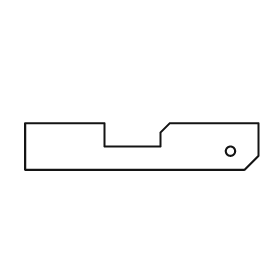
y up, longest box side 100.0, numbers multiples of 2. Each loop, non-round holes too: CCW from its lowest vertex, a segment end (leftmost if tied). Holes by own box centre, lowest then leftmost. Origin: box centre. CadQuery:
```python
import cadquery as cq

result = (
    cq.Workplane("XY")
    .moveTo(-50.0, -10.0)
    .lineTo(44.0, -10.0)
    .lineTo(50.0, -4.0)
    .lineTo(50.0, 10.0)
    .lineTo(12.0, 10.0)
    .lineTo(8.0, 6.0)
    .lineTo(8.0, 0.0)
    .lineTo(-16.0, 0.0)
    .lineTo(-16.0, 10.0)
    .lineTo(-50.0, 10.0)
    .close()
    .moveTo(38.0, -2.0)
    .circle(2.0)
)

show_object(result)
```